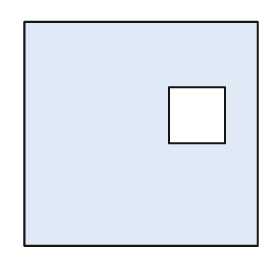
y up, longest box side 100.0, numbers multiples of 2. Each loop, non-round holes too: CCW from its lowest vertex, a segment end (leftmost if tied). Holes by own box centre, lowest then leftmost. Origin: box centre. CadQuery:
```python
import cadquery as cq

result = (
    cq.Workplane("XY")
    .moveTo(-50.0, -48.0)
    .lineTo(50.0, -48.0)
    .lineTo(50.0, 48.0)
    .lineTo(-50.0, 48.0)
    .close()
    .moveTo(12.0, -4.0)
    .lineTo(36.0, -4.0)
    .lineTo(36.0, 20.0)
    .lineTo(12.0, 20.0)
    .close()
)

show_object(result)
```